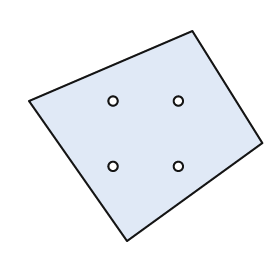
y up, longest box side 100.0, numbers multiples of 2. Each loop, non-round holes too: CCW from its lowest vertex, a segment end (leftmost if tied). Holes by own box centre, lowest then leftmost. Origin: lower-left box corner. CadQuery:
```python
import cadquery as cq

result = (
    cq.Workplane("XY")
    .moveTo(42.0, 0.0)
    .lineTo(100.0, 42.0)
    .lineTo(70.0, 90.0)
    .lineTo(0.0, 60.0)
    .close()
    .moveTo(36.0, 32.0)
    .circle(2.0)
    .moveTo(64.0, 32.0)
    .circle(2.0)
    .moveTo(36.0, 60.0)
    .circle(2.0)
    .moveTo(64.0, 60.0)
    .circle(2.0)
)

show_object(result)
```